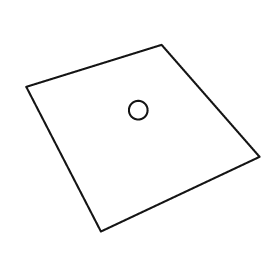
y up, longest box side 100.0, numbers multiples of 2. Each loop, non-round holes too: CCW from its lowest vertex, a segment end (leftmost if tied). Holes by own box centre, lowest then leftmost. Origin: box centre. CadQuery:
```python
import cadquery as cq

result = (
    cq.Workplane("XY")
    .moveTo(-18.0, -40.0)
    .lineTo(50.0, -8.0)
    .lineTo(8.0, 40.0)
    .lineTo(-50.0, 22.0)
    .close()
    .moveTo(-2.0, 12.0)
    .circle(4.0)
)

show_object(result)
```